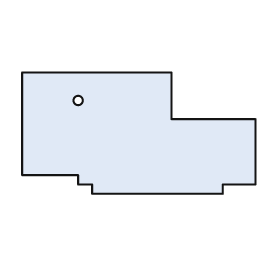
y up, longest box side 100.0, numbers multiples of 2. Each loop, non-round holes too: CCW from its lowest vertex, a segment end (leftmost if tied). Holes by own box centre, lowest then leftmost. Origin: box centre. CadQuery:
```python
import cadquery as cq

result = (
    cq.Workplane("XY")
    .moveTo(-20.0, -26.0)
    .lineTo(36.0, -26.0)
    .lineTo(36.0, -22.0)
    .lineTo(50.0, -22.0)
    .lineTo(50.0, 6.0)
    .lineTo(14.0, 6.0)
    .lineTo(14.0, 26.0)
    .lineTo(-50.0, 26.0)
    .lineTo(-50.0, -18.0)
    .lineTo(-26.0, -18.0)
    .lineTo(-26.0, -22.0)
    .lineTo(-20.0, -22.0)
    .close()
    .moveTo(-26.0, 14.0)
    .circle(2.0)
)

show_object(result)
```